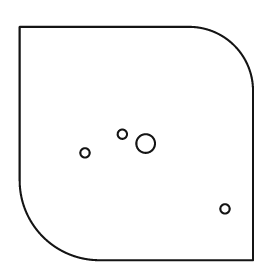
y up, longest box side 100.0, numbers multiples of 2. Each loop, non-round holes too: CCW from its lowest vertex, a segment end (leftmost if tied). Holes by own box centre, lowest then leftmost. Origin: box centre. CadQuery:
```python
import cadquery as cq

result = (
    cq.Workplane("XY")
    .moveTo(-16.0, -50.0)
    .lineTo(50.0, -50.0)
    .lineTo(50.0, 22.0)
    .threePointArc((42.0, 42.0), (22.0, 50.0))
    .lineTo(-50.0, 50.0)
    .lineTo(-50.0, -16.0)
    .threePointArc((-40.0, -40.0), (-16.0, -50.0))
    .close()
    .moveTo(38.0, -28.0)
    .circle(2.0)
    .moveTo(-22.0, -4.0)
    .circle(2.0)
    .moveTo(4.0, 0.0)
    .circle(4.0)
    .moveTo(-6.0, 4.0)
    .circle(2.0)
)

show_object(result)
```